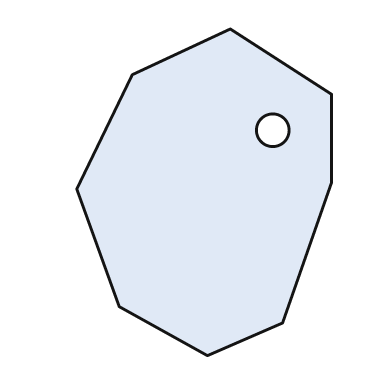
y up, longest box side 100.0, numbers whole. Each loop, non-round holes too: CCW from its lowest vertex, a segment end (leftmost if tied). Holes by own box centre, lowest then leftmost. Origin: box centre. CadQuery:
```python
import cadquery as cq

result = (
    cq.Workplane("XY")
    .moveTo(1.0, -50.0)
    .lineTo(24.0, -40.0)
    .lineTo(39.0, 3.0)
    .lineTo(39.0, 30.0)
    .lineTo(8.0, 50.0)
    .lineTo(-22.0, 36.0)
    .lineTo(-39.0, 1.0)
    .lineTo(-26.0, -35.0)
    .close()
    .moveTo(21.0, 19.0)
    .circle(5.0)
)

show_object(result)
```